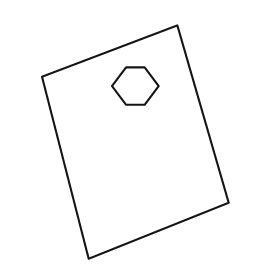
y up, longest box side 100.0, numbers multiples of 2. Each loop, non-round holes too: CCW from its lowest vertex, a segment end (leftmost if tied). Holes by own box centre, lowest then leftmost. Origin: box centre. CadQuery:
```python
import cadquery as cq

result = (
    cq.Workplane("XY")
    .moveTo(-20.0, -50.0)
    .lineTo(40.0, -26.0)
    .lineTo(18.0, 50.0)
    .lineTo(-40.0, 28.0)
    .close()
    .moveTo(-4.0, 16.0)
    .lineTo(4.0, 16.0)
    .lineTo(10.0, 24.0)
    .lineTo(4.0, 32.0)
    .lineTo(-4.0, 32.0)
    .lineTo(-10.0, 24.0)
    .close()
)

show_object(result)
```